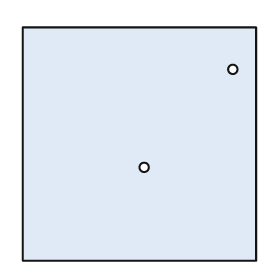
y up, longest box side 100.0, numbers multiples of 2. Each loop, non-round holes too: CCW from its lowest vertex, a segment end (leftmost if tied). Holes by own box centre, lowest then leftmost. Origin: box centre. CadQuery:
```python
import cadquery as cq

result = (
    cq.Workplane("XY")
    .moveTo(-50.0, -50.0)
    .lineTo(50.0, -50.0)
    .lineTo(50.0, 50.0)
    .lineTo(-50.0, 50.0)
    .close()
    .moveTo(2.0, -10.0)
    .circle(2.0)
    .moveTo(40.0, 32.0)
    .circle(2.0)
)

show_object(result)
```